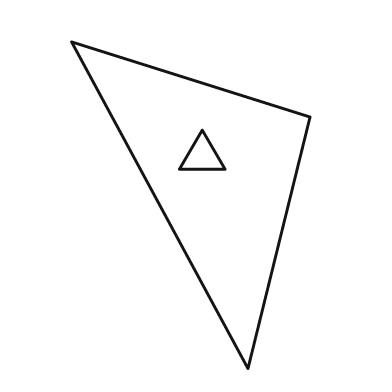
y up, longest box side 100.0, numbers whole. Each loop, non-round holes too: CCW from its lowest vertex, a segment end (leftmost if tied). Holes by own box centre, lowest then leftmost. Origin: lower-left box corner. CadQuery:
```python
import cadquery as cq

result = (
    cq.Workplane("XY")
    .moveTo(54.0, 0.0)
    .lineTo(73.0, 77.0)
    .lineTo(0.0, 100.0)
    .close()
    .moveTo(33.0, 61.0)
    .lineTo(47.0, 61.0)
    .lineTo(40.0, 73.0)
    .close()
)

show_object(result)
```